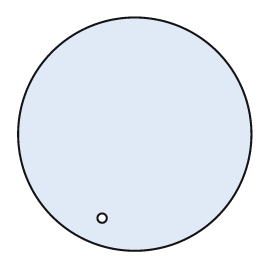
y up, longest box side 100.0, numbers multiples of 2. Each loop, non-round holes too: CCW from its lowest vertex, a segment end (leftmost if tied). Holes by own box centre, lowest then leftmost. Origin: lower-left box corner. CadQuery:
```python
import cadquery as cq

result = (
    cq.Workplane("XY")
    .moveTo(50.0, 50.0)
    .circle(50.0)
    .moveTo(36.0, 14.0)
    .circle(2.0)
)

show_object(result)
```